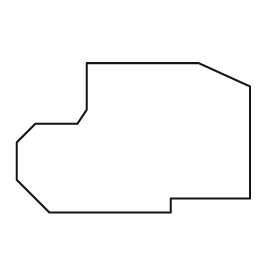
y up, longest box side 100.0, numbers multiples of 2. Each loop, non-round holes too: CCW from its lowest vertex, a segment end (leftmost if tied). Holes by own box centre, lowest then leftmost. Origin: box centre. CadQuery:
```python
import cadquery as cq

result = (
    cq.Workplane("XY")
    .moveTo(-36.0, -32.0)
    .lineTo(16.0, -32.0)
    .lineTo(16.0, -26.0)
    .lineTo(50.0, -26.0)
    .lineTo(50.0, 22.0)
    .lineTo(28.0, 32.0)
    .lineTo(-20.0, 32.0)
    .lineTo(-20.0, 12.0)
    .lineTo(-24.0, 6.0)
    .lineTo(-42.0, 6.0)
    .lineTo(-50.0, -2.0)
    .lineTo(-50.0, -18.0)
    .close()
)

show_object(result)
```